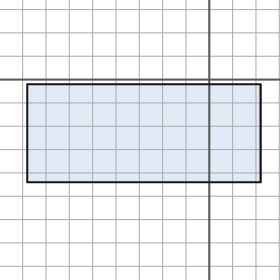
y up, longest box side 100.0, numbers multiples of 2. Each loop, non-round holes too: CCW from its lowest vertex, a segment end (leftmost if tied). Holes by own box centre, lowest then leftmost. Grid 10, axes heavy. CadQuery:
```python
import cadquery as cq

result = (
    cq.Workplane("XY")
    .moveTo(-78.0, -44.0)
    .lineTo(22.0, -44.0)
    .lineTo(22.0, -2.0)
    .lineTo(-78.0, -2.0)
    .close()
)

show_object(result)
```